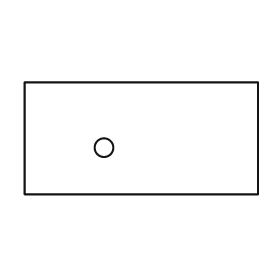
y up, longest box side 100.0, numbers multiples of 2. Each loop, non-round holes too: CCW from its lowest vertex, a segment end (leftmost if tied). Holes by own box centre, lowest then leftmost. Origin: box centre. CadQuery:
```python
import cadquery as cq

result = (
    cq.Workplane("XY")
    .moveTo(-50.0, -24.0)
    .lineTo(50.0, -24.0)
    .lineTo(50.0, 24.0)
    .lineTo(-50.0, 24.0)
    .close()
    .moveTo(-16.0, -4.0)
    .circle(4.0)
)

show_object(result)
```